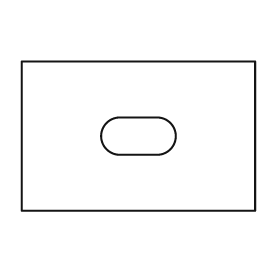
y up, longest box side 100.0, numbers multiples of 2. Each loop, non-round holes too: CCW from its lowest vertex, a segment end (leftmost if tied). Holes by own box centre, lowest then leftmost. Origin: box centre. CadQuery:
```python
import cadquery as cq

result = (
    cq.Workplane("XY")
    .moveTo(-50.0, -32.0)
    .lineTo(50.0, -32.0)
    .lineTo(50.0, 32.0)
    .lineTo(-50.0, 32.0)
    .close()
    .moveTo(-8.0, -8.0)
    .lineTo(8.0, -8.0)
    .threePointArc((16.0, 0.0), (8.0, 8.0))
    .lineTo(-8.0, 8.0)
    .threePointArc((-16.0, 0.0), (-8.0, -8.0))
    .close()
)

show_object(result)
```